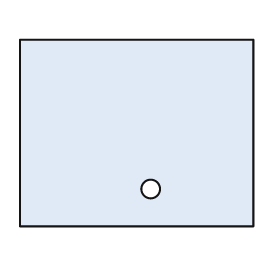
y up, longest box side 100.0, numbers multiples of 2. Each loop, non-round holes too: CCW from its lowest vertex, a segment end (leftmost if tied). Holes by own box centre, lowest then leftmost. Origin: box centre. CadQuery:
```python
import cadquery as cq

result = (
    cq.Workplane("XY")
    .moveTo(-50.0, -40.0)
    .lineTo(50.0, -40.0)
    .lineTo(50.0, 40.0)
    .lineTo(-50.0, 40.0)
    .close()
    .moveTo(6.0, -24.0)
    .circle(4.0)
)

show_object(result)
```